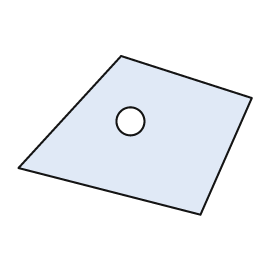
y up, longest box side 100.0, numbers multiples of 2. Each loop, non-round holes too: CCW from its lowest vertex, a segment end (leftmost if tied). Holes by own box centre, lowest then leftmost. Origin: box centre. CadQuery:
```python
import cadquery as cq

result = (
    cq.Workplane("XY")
    .moveTo(28.0, -34.0)
    .lineTo(50.0, 16.0)
    .lineTo(-6.0, 34.0)
    .lineTo(-50.0, -14.0)
    .close()
    .moveTo(-2.0, 6.0)
    .circle(6.0)
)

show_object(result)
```